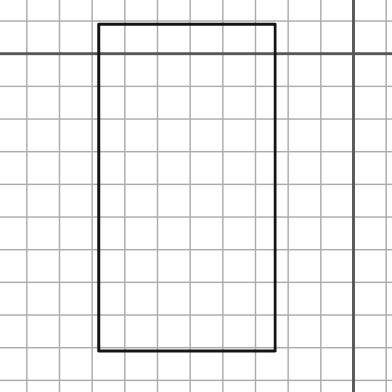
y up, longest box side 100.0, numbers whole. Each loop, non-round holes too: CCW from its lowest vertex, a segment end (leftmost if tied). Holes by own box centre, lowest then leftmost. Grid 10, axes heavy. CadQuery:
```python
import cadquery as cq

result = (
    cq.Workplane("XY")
    .moveTo(-78.0, -91.0)
    .lineTo(-24.0, -91.0)
    .lineTo(-24.0, 9.0)
    .lineTo(-78.0, 9.0)
    .close()
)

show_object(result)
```